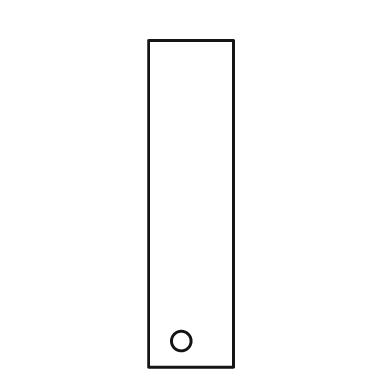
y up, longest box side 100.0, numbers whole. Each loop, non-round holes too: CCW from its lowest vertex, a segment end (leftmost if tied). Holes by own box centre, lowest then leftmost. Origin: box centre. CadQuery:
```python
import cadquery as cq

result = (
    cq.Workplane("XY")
    .moveTo(-13.0, -50.0)
    .lineTo(13.0, -50.0)
    .lineTo(13.0, 50.0)
    .lineTo(-13.0, 50.0)
    .close()
    .moveTo(-3.0, -42.0)
    .circle(3.0)
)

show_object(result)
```